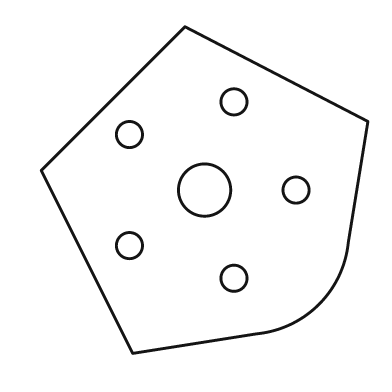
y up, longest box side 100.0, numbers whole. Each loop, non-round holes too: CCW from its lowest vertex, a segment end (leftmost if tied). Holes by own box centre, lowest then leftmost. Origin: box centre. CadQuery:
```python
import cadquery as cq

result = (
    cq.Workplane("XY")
    .moveTo(-22.0, -50.0)
    .lineTo(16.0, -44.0)
    .threePointArc((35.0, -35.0), (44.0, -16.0))
    .lineTo(50.0, 21.0)
    .lineTo(-6.0, 50.0)
    .lineTo(-50.0, 6.0)
    .close()
    .moveTo(9.0, -27.0)
    .circle(4.0)
    .moveTo(-23.0, -17.0)
    .circle(4.0)
    .moveTo(0.0, 0.0)
    .circle(8.0)
    .moveTo(28.0, 0.0)
    .circle(4.0)
    .moveTo(-23.0, 17.0)
    .circle(4.0)
    .moveTo(9.0, 27.0)
    .circle(4.0)
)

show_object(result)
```